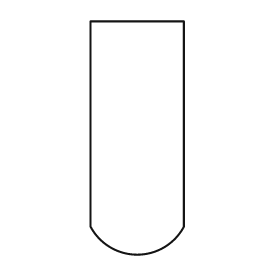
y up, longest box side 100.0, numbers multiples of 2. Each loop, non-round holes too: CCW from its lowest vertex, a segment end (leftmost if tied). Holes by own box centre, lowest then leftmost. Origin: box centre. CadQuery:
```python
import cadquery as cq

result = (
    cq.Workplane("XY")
    .moveTo(-20.0, -38.0)
    .threePointArc((0.0, -50.0), (20.0, -38.0))
    .lineTo(20.0, 50.0)
    .lineTo(-20.0, 50.0)
    .close()
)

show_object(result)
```